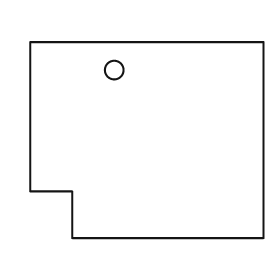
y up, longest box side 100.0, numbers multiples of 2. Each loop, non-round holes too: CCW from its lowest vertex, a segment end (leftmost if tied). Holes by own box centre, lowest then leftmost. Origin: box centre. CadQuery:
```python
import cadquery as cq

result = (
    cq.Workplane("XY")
    .moveTo(-32.0, -42.0)
    .lineTo(50.0, -42.0)
    .lineTo(50.0, 42.0)
    .lineTo(-50.0, 42.0)
    .lineTo(-50.0, -22.0)
    .lineTo(-32.0, -22.0)
    .close()
    .moveTo(-14.0, 30.0)
    .circle(4.0)
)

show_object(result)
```